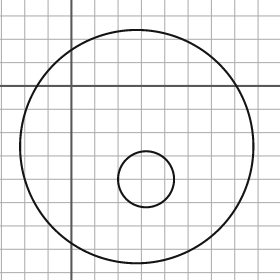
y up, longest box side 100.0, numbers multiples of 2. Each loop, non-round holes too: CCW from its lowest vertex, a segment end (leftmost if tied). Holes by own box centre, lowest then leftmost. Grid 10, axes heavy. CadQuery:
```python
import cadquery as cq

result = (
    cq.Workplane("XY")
    .moveTo(28.0, -26.0)
    .circle(50.0)
    .moveTo(32.0, -40.0)
    .circle(12.0)
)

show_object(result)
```